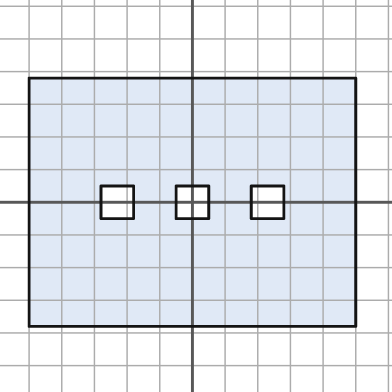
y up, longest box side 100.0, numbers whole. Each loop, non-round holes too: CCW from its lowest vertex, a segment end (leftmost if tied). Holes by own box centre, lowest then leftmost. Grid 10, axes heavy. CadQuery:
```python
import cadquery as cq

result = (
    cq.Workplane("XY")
    .moveTo(-50.0, -38.0)
    .lineTo(50.0, -38.0)
    .lineTo(50.0, 38.0)
    .lineTo(-50.0, 38.0)
    .close()
    .moveTo(-28.0, -5.0)
    .lineTo(-18.0, -5.0)
    .lineTo(-18.0, 5.0)
    .lineTo(-28.0, 5.0)
    .close()
    .moveTo(-5.0, -5.0)
    .lineTo(5.0, -5.0)
    .lineTo(5.0, 5.0)
    .lineTo(-5.0, 5.0)
    .close()
    .moveTo(18.0, -5.0)
    .lineTo(28.0, -5.0)
    .lineTo(28.0, 5.0)
    .lineTo(18.0, 5.0)
    .close()
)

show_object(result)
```